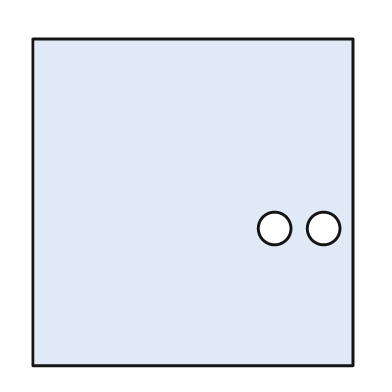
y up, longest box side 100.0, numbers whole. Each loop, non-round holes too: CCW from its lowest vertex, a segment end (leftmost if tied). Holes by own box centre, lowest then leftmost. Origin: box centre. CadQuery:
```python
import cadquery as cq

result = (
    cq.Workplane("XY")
    .moveTo(-49.0, -50.0)
    .lineTo(49.0, -50.0)
    .lineTo(49.0, 50.0)
    .lineTo(-49.0, 50.0)
    .close()
    .moveTo(25.0, -8.0)
    .circle(5.0)
    .moveTo(40.0, -8.0)
    .circle(5.0)
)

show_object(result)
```